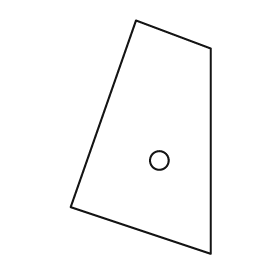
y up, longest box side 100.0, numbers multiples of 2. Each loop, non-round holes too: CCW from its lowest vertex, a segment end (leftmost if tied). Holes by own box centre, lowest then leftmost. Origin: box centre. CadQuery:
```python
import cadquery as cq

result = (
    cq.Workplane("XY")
    .moveTo(30.0, -50.0)
    .lineTo(30.0, 38.0)
    .lineTo(-2.0, 50.0)
    .lineTo(-30.0, -30.0)
    .close()
    .moveTo(8.0, -10.0)
    .circle(4.0)
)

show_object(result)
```